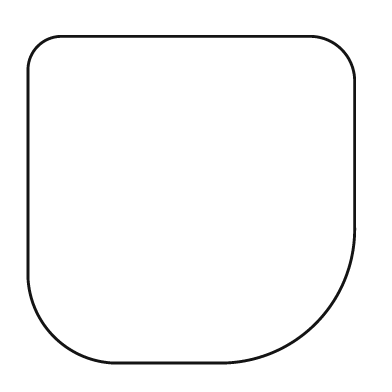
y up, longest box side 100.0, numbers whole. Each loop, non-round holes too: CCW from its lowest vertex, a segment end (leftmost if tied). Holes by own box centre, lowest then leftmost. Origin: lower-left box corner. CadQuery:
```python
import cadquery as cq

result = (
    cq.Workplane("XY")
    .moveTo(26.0, 0.0)
    .lineTo(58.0, 0.0)
    .threePointArc((88.0, 12.0), (100.0, 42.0))
    .lineTo(100.0, 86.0)
    .threePointArc((96.0, 96.0), (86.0, 100.0))
    .lineTo(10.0, 100.0)
    .threePointArc((3.0, 97.0), (0.0, 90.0))
    .lineTo(0.0, 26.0)
    .threePointArc((8.0, 8.0), (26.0, 0.0))
    .close()
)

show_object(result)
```